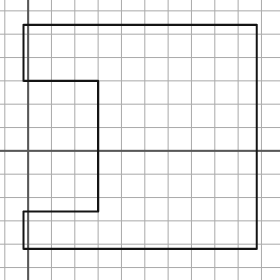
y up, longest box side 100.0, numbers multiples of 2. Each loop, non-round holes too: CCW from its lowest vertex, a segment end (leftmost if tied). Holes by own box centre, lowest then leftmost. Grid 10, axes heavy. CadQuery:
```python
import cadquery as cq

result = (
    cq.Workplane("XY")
    .moveTo(-2.0, -42.0)
    .lineTo(98.0, -42.0)
    .lineTo(98.0, 54.0)
    .lineTo(-2.0, 54.0)
    .lineTo(-2.0, 30.0)
    .lineTo(30.0, 30.0)
    .lineTo(30.0, -26.0)
    .lineTo(-2.0, -26.0)
    .close()
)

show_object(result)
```